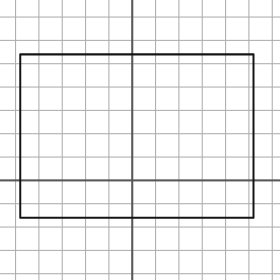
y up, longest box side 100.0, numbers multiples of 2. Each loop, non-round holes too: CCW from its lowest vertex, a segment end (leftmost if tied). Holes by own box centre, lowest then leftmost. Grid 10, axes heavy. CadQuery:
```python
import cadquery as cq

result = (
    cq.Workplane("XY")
    .moveTo(-48.0, -16.0)
    .lineTo(52.0, -16.0)
    .lineTo(52.0, 54.0)
    .lineTo(-48.0, 54.0)
    .close()
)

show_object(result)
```